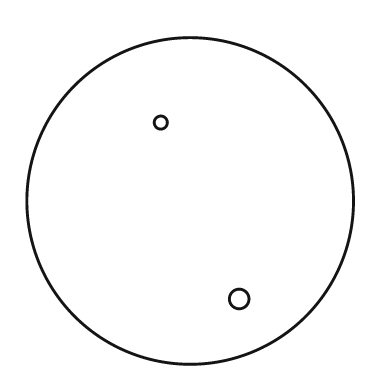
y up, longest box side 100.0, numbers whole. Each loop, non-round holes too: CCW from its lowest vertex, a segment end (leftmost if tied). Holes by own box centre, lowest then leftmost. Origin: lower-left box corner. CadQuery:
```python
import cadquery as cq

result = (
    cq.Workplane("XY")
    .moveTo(50.0, 50.0)
    .circle(50.0)
    .moveTo(65.0, 20.0)
    .circle(3.0)
    .moveTo(41.0, 74.0)
    .circle(2.0)
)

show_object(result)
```